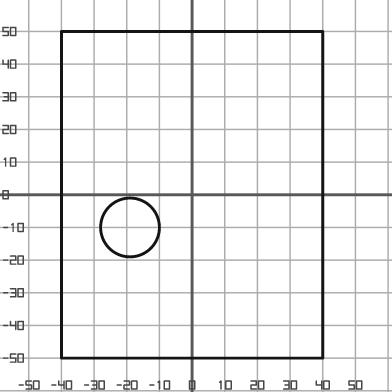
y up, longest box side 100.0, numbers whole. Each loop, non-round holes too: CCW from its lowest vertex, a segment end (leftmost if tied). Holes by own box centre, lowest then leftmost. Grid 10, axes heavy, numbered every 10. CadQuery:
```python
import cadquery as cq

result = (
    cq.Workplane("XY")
    .moveTo(-40.0, -50.0)
    .lineTo(40.0, -50.0)
    .lineTo(40.0, 50.0)
    .lineTo(-40.0, 50.0)
    .close()
    .moveTo(-19.0, -10.0)
    .circle(9.0)
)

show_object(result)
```